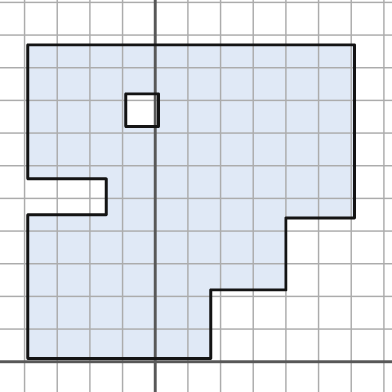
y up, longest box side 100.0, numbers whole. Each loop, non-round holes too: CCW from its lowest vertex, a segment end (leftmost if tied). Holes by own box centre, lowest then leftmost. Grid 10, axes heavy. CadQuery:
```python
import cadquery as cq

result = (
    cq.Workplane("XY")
    .moveTo(-39.0, 1.0)
    .lineTo(17.0, 1.0)
    .lineTo(17.0, 22.0)
    .lineTo(40.0, 22.0)
    .lineTo(40.0, 44.0)
    .lineTo(61.0, 44.0)
    .lineTo(61.0, 97.0)
    .lineTo(-39.0, 97.0)
    .lineTo(-39.0, 56.0)
    .lineTo(-15.0, 56.0)
    .lineTo(-15.0, 45.0)
    .lineTo(-39.0, 45.0)
    .close()
    .moveTo(-9.0, 72.0)
    .lineTo(1.0, 72.0)
    .lineTo(1.0, 82.0)
    .lineTo(-9.0, 82.0)
    .close()
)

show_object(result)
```